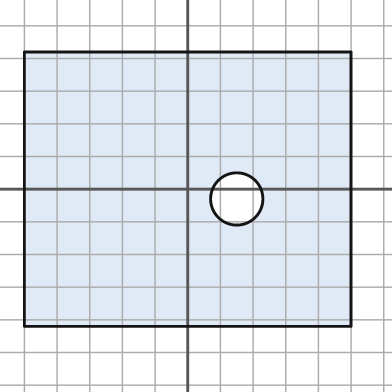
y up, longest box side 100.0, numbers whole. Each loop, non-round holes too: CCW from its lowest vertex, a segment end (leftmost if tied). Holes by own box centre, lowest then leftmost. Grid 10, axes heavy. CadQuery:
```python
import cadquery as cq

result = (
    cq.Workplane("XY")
    .moveTo(-50.0, -42.0)
    .lineTo(50.0, -42.0)
    .lineTo(50.0, 42.0)
    .lineTo(-50.0, 42.0)
    .close()
    .moveTo(15.0, -3.0)
    .circle(8.0)
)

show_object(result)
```